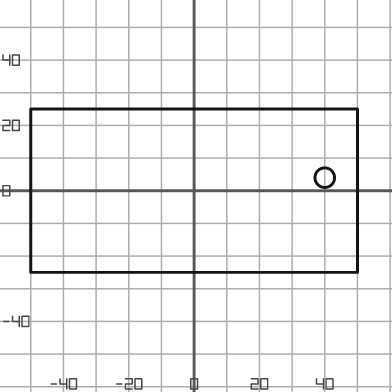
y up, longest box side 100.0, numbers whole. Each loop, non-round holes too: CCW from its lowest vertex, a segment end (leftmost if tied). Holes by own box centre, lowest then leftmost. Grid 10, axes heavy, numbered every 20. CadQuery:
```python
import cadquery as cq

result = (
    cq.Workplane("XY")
    .moveTo(-50.0, -25.0)
    .lineTo(50.0, -25.0)
    .lineTo(50.0, 25.0)
    .lineTo(-50.0, 25.0)
    .close()
    .moveTo(40.0, 4.0)
    .circle(3.0)
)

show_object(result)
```